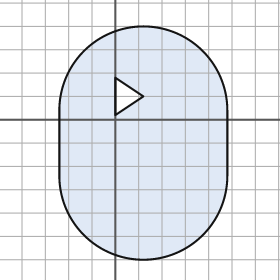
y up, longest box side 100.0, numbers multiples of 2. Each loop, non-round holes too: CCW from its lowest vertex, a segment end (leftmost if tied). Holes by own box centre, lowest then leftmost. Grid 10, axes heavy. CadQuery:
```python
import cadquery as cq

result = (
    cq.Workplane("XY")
    .moveTo(-24.0, -24.0)
    .threePointArc((12.0, -60.0), (48.0, -24.0))
    .lineTo(48.0, 4.0)
    .threePointArc((12.0, 40.0), (-24.0, 4.0))
    .close()
    .moveTo(0.0, 2.0)
    .lineTo(12.0, 10.0)
    .lineTo(0.0, 18.0)
    .close()
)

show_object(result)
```